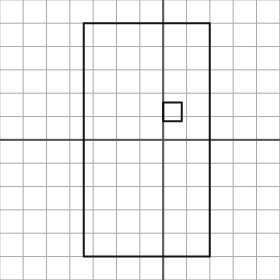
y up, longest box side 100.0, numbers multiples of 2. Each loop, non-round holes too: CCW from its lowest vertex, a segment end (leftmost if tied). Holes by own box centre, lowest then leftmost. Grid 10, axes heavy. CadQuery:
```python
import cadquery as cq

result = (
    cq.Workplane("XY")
    .moveTo(-34.0, -50.0)
    .lineTo(20.0, -50.0)
    .lineTo(20.0, 50.0)
    .lineTo(-34.0, 50.0)
    .close()
    .moveTo(0.0, 8.0)
    .lineTo(8.0, 8.0)
    .lineTo(8.0, 16.0)
    .lineTo(0.0, 16.0)
    .close()
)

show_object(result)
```